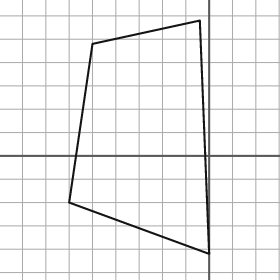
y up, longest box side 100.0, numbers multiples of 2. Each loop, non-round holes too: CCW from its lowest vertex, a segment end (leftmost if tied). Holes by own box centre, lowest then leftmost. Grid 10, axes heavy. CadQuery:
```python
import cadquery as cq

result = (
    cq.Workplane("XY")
    .moveTo(0.0, -42.0)
    .lineTo(-4.0, 58.0)
    .lineTo(-50.0, 48.0)
    .lineTo(-60.0, -20.0)
    .close()
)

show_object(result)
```